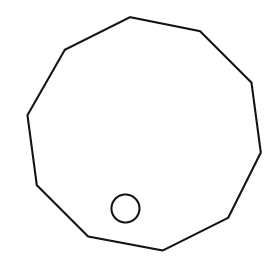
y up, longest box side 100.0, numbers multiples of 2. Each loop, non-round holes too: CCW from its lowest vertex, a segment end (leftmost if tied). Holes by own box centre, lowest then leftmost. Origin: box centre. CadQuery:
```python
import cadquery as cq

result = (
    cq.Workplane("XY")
    .moveTo(8.0, -50.0)
    .lineTo(36.0, -36.0)
    .lineTo(50.0, -8.0)
    .lineTo(46.0, 22.0)
    .lineTo(24.0, 44.0)
    .lineTo(-6.0, 50.0)
    .lineTo(-34.0, 36.0)
    .lineTo(-50.0, 8.0)
    .lineTo(-46.0, -22.0)
    .lineTo(-24.0, -44.0)
    .close()
    .moveTo(-8.0, -32.0)
    .circle(6.0)
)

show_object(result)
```